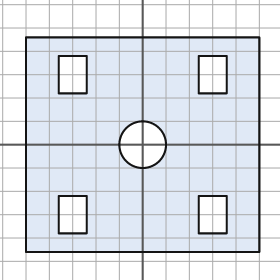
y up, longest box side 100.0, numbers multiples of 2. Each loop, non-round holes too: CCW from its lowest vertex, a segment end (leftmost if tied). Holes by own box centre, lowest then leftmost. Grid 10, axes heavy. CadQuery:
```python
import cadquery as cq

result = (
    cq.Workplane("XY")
    .moveTo(-50.0, -46.0)
    .lineTo(50.0, -46.0)
    .lineTo(50.0, 46.0)
    .lineTo(-50.0, 46.0)
    .close()
    .moveTo(-36.0, -38.0)
    .lineTo(-24.0, -38.0)
    .lineTo(-24.0, -22.0)
    .lineTo(-36.0, -22.0)
    .close()
    .moveTo(24.0, -38.0)
    .lineTo(36.0, -38.0)
    .lineTo(36.0, -22.0)
    .lineTo(24.0, -22.0)
    .close()
    .moveTo(0.0, 0.0)
    .circle(10.0)
    .moveTo(-36.0, 22.0)
    .lineTo(-24.0, 22.0)
    .lineTo(-24.0, 38.0)
    .lineTo(-36.0, 38.0)
    .close()
    .moveTo(24.0, 22.0)
    .lineTo(36.0, 22.0)
    .lineTo(36.0, 38.0)
    .lineTo(24.0, 38.0)
    .close()
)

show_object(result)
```